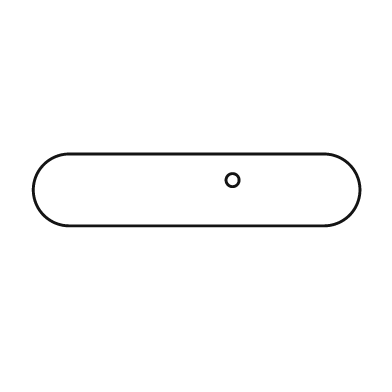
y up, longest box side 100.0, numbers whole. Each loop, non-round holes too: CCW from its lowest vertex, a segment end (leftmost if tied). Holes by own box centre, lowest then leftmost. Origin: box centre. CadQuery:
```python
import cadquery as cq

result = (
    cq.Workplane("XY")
    .moveTo(-39.0, -11.0)
    .lineTo(39.0, -11.0)
    .threePointArc((50.0, 0.0), (39.0, 11.0))
    .lineTo(-39.0, 11.0)
    .threePointArc((-50.0, 0.0), (-39.0, -11.0))
    .close()
    .moveTo(11.0, 3.0)
    .circle(2.0)
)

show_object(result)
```